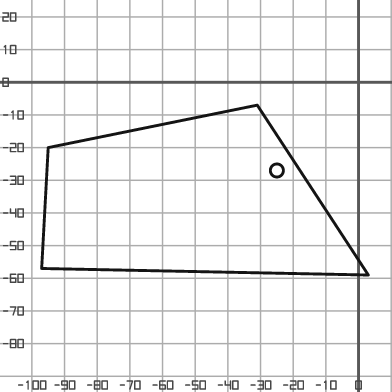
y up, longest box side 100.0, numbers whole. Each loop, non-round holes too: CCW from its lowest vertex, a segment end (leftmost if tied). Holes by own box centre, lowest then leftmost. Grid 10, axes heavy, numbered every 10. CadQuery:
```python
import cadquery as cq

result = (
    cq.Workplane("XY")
    .moveTo(3.0, -59.0)
    .lineTo(-31.0, -7.0)
    .lineTo(-95.0, -20.0)
    .lineTo(-97.0, -57.0)
    .close()
    .moveTo(-25.0, -27.0)
    .circle(2.0)
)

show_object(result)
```